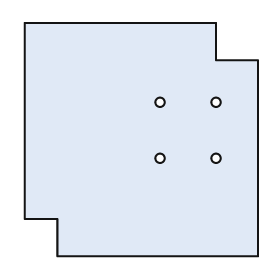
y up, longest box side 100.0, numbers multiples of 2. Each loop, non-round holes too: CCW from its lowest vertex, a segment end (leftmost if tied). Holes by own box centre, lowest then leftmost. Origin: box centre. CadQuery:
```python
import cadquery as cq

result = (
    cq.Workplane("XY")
    .moveTo(-36.0, -50.0)
    .lineTo(50.0, -50.0)
    .lineTo(50.0, 34.0)
    .lineTo(32.0, 34.0)
    .lineTo(32.0, 50.0)
    .lineTo(-50.0, 50.0)
    .lineTo(-50.0, -34.0)
    .lineTo(-36.0, -34.0)
    .close()
    .moveTo(8.0, -8.0)
    .circle(2.0)
    .moveTo(32.0, -8.0)
    .circle(2.0)
    .moveTo(8.0, 16.0)
    .circle(2.0)
    .moveTo(32.0, 16.0)
    .circle(2.0)
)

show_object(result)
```